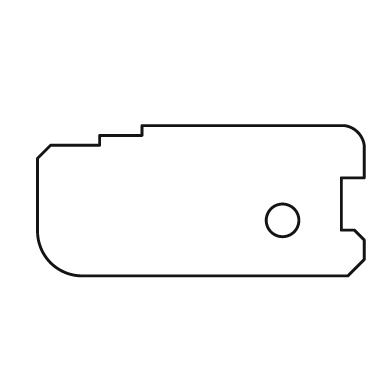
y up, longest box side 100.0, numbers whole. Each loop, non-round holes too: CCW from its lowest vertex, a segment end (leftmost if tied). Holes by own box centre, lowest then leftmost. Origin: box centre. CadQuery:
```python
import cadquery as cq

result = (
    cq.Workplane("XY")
    .moveTo(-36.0, -23.0)
    .lineTo(45.0, -23.0)
    .lineTo(50.0, -18.0)
    .lineTo(50.0, -12.0)
    .lineTo(47.0, -9.0)
    .lineTo(43.0, -9.0)
    .lineTo(43.0, 7.0)
    .lineTo(50.0, 7.0)
    .lineTo(50.0, 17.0)
    .threePointArc((48.0, 21.0), (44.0, 23.0))
    .lineTo(-18.0, 23.0)
    .lineTo(-18.0, 20.0)
    .lineTo(-31.0, 20.0)
    .lineTo(-31.0, 17.0)
    .lineTo(-46.0, 17.0)
    .lineTo(-50.0, 13.0)
    .lineTo(-50.0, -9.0)
    .threePointArc((-46.0, -19.0), (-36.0, -23.0))
    .close()
    .moveTo(25.0, -6.0)
    .circle(5.0)
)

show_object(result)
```